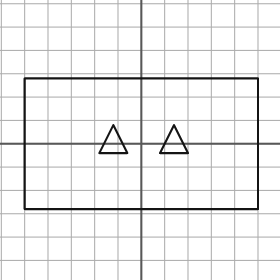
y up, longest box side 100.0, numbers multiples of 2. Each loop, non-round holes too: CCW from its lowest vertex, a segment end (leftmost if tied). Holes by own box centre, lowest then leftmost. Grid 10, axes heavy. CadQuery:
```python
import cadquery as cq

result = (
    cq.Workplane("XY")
    .moveTo(-50.0, -28.0)
    .lineTo(50.0, -28.0)
    .lineTo(50.0, 28.0)
    .lineTo(-50.0, 28.0)
    .close()
    .moveTo(-18.0, -4.0)
    .lineTo(-6.0, -4.0)
    .lineTo(-12.0, 8.0)
    .close()
    .moveTo(8.0, -4.0)
    .lineTo(20.0, -4.0)
    .lineTo(14.0, 8.0)
    .close()
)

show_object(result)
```